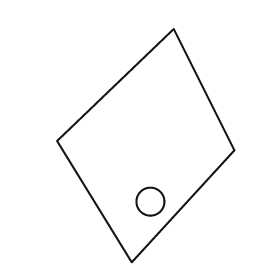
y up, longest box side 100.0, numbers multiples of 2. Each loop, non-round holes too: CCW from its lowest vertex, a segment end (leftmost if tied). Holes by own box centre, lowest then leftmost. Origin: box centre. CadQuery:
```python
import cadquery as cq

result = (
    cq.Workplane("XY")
    .moveTo(-6.0, -50.0)
    .lineTo(38.0, -2.0)
    .lineTo(12.0, 50.0)
    .lineTo(-38.0, 2.0)
    .close()
    .moveTo(2.0, -24.0)
    .circle(6.0)
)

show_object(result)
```